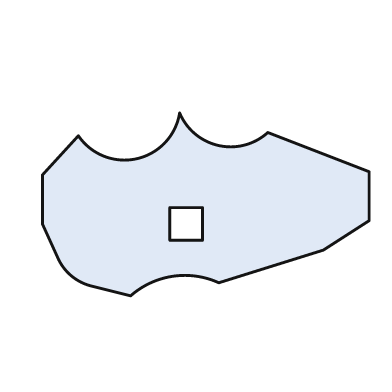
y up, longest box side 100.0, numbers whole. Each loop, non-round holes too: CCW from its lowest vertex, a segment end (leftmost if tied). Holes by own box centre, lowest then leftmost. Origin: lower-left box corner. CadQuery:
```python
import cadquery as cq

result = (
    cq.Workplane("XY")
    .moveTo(27.0, 0.0)
    .threePointArc((40.0, 6.0), (54.0, 4.0))
    .lineTo(86.0, 14.0)
    .lineTo(100.0, 23.0)
    .lineTo(100.0, 38.0)
    .lineTo(69.0, 50.0)
    .threePointArc((54.0, 46.0), (42.0, 56.0))
    .threePointArc((29.0, 42.0), (11.0, 49.0))
    .lineTo(0.0, 37.0)
    .lineTo(0.0, 22.0)
    .lineTo(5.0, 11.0)
    .threePointArc((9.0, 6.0), (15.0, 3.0))
    .close()
    .moveTo(39.0, 17.0)
    .lineTo(49.0, 17.0)
    .lineTo(49.0, 27.0)
    .lineTo(39.0, 27.0)
    .close()
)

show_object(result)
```